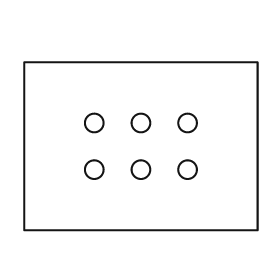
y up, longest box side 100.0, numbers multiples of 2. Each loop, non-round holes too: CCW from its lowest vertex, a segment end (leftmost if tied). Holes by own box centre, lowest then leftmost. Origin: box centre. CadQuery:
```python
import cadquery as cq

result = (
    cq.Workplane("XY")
    .moveTo(-50.0, -36.0)
    .lineTo(50.0, -36.0)
    .lineTo(50.0, 36.0)
    .lineTo(-50.0, 36.0)
    .close()
    .moveTo(-20.0, -10.0)
    .circle(4.0)
    .moveTo(0.0, -10.0)
    .circle(4.0)
    .moveTo(20.0, -10.0)
    .circle(4.0)
    .moveTo(-20.0, 10.0)
    .circle(4.0)
    .moveTo(0.0, 10.0)
    .circle(4.0)
    .moveTo(20.0, 10.0)
    .circle(4.0)
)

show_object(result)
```